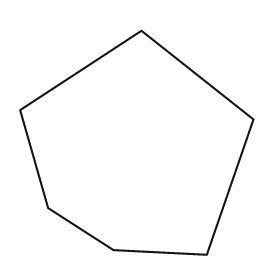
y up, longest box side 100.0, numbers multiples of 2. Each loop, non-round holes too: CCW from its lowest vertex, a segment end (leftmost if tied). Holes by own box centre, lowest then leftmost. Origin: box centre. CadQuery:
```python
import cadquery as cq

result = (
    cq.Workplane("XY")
    .moveTo(30.0, -48.0)
    .lineTo(50.0, 10.0)
    .lineTo(2.0, 48.0)
    .lineTo(-50.0, 14.0)
    .lineTo(-38.0, -28.0)
    .lineTo(-10.0, -46.0)
    .close()
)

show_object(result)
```